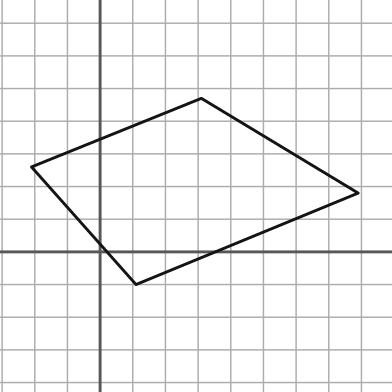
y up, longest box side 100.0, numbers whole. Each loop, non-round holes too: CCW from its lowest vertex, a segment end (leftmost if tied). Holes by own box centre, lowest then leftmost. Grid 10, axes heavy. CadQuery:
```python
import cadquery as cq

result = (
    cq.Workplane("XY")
    .moveTo(11.0, -10.0)
    .lineTo(79.0, 18.0)
    .lineTo(31.0, 47.0)
    .lineTo(-21.0, 26.0)
    .close()
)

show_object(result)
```